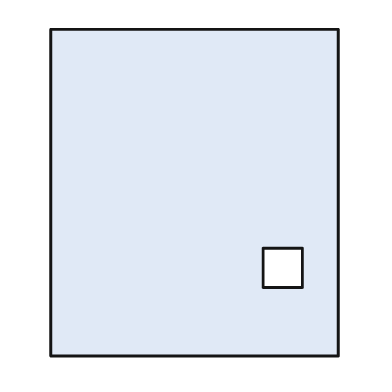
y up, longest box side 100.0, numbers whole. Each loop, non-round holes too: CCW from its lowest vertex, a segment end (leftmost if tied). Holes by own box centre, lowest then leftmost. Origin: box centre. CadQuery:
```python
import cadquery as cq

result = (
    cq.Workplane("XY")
    .moveTo(-44.0, -50.0)
    .lineTo(44.0, -50.0)
    .lineTo(44.0, 50.0)
    .lineTo(-44.0, 50.0)
    .close()
    .moveTo(21.0, -29.0)
    .lineTo(33.0, -29.0)
    .lineTo(33.0, -17.0)
    .lineTo(21.0, -17.0)
    .close()
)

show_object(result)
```